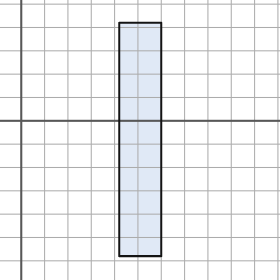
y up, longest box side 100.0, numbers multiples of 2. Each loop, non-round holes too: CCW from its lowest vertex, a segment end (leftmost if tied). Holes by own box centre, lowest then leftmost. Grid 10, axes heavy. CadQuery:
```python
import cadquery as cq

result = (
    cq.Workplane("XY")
    .moveTo(42.0, -58.0)
    .lineTo(60.0, -58.0)
    .lineTo(60.0, 42.0)
    .lineTo(42.0, 42.0)
    .close()
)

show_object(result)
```